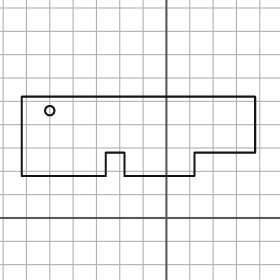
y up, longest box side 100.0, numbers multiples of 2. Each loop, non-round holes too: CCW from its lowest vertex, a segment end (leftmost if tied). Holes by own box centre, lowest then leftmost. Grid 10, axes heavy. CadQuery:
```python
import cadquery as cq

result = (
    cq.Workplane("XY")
    .moveTo(-62.0, 18.0)
    .lineTo(-26.0, 18.0)
    .lineTo(-26.0, 28.0)
    .lineTo(-18.0, 28.0)
    .lineTo(-18.0, 18.0)
    .lineTo(12.0, 18.0)
    .lineTo(12.0, 28.0)
    .lineTo(38.0, 28.0)
    .lineTo(38.0, 52.0)
    .lineTo(-62.0, 52.0)
    .close()
    .moveTo(-50.0, 46.0)
    .circle(2.0)
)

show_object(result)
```